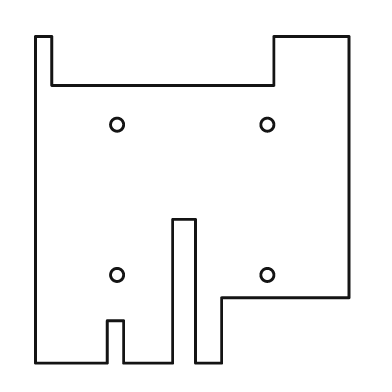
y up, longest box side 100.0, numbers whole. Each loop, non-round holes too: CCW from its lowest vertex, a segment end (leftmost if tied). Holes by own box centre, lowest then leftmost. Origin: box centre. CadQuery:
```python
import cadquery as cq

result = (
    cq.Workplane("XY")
    .moveTo(-48.0, -50.0)
    .lineTo(-26.0, -50.0)
    .lineTo(-26.0, -37.0)
    .lineTo(-21.0, -37.0)
    .lineTo(-21.0, -50.0)
    .lineTo(-6.0, -50.0)
    .lineTo(-6.0, -6.0)
    .lineTo(1.0, -6.0)
    .lineTo(1.0, -50.0)
    .lineTo(9.0, -50.0)
    .lineTo(9.0, -30.0)
    .lineTo(48.0, -30.0)
    .lineTo(48.0, 50.0)
    .lineTo(25.0, 50.0)
    .lineTo(25.0, 35.0)
    .lineTo(-43.0, 35.0)
    .lineTo(-43.0, 50.0)
    .lineTo(-48.0, 50.0)
    .close()
    .moveTo(-23.0, -23.0)
    .circle(2.0)
    .moveTo(23.0, -23.0)
    .circle(2.0)
    .moveTo(-23.0, 23.0)
    .circle(2.0)
    .moveTo(23.0, 23.0)
    .circle(2.0)
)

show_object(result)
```